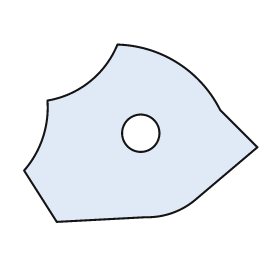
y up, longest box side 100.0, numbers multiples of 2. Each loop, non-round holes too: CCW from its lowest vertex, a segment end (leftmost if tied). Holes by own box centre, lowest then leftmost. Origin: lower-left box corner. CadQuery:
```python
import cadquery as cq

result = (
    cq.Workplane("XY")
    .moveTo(14.0, 0.0)
    .lineTo(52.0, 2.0)
    .threePointArc((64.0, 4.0), (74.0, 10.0))
    .lineTo(100.0, 32.0)
    .lineTo(84.0, 48.0)
    .threePointArc((66.0, 68.0), (40.0, 76.0))
    .threePointArc((28.0, 60.0), (10.0, 52.0))
    .threePointArc((8.0, 36.0), (0.0, 22.0))
    .close()
    .moveTo(50.0, 38.0)
    .circle(8.0)
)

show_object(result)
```